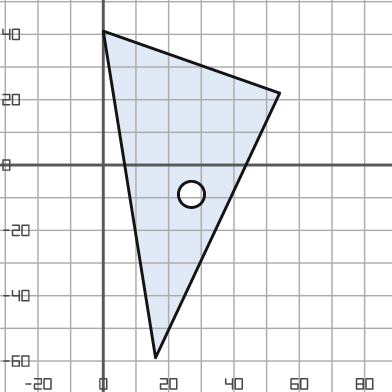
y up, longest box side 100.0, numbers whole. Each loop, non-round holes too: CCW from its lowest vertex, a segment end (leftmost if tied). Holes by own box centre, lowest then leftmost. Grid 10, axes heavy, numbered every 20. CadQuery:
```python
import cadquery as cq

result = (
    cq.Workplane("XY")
    .moveTo(16.0, -59.0)
    .lineTo(54.0, 22.0)
    .lineTo(0.0, 41.0)
    .close()
    .moveTo(27.0, -9.0)
    .circle(4.0)
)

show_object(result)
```